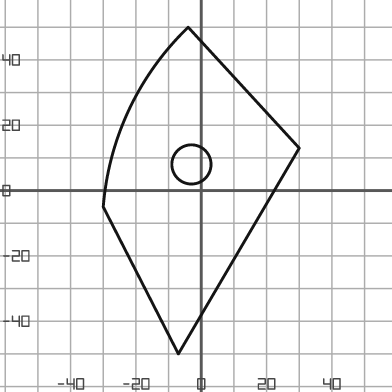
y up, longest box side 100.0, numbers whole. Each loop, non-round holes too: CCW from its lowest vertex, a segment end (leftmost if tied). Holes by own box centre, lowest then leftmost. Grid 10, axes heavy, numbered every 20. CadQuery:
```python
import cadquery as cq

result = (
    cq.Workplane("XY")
    .moveTo(-7.0, -50.0)
    .lineTo(30.0, 13.0)
    .lineTo(-4.0, 50.0)
    .threePointArc((-22.0, 25.0), (-30.0, -5.0))
    .close()
    .moveTo(-3.0, 8.0)
    .circle(6.0)
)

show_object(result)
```